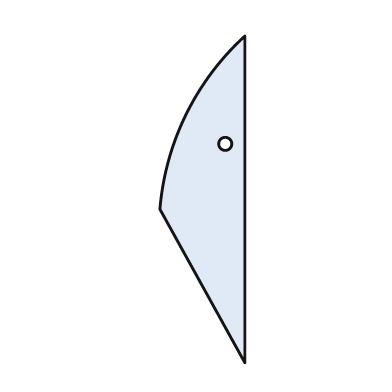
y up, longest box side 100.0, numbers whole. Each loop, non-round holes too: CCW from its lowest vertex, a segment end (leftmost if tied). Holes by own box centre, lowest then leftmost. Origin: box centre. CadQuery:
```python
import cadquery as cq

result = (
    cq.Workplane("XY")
    .moveTo(13.0, -50.0)
    .lineTo(13.0, 50.0)
    .threePointArc((-5.0, 26.0), (-13.0, -3.0))
    .close()
    .moveTo(7.0, 17.0)
    .circle(2.0)
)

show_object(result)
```